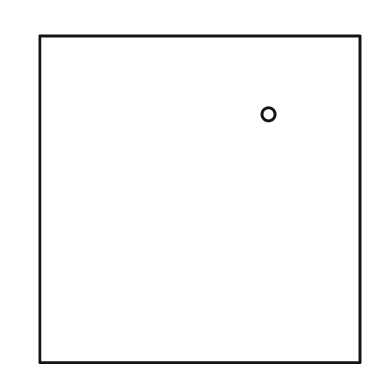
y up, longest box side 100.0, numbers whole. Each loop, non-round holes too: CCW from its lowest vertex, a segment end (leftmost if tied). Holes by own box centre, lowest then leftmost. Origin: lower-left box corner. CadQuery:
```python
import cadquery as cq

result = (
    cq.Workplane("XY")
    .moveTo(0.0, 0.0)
    .lineTo(98.0, 0.0)
    .lineTo(98.0, 100.0)
    .lineTo(0.0, 100.0)
    .close()
    .moveTo(70.0, 76.0)
    .circle(2.0)
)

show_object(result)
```